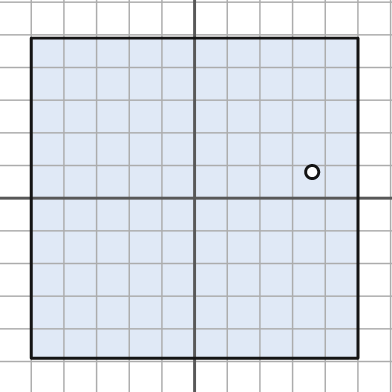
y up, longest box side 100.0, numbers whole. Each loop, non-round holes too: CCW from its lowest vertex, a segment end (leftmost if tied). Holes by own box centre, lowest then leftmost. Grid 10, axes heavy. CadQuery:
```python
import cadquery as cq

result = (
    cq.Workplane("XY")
    .moveTo(-50.0, -49.0)
    .lineTo(50.0, -49.0)
    .lineTo(50.0, 49.0)
    .lineTo(-50.0, 49.0)
    .close()
    .moveTo(36.0, 8.0)
    .circle(2.0)
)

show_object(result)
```